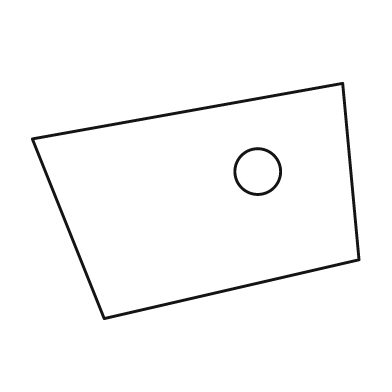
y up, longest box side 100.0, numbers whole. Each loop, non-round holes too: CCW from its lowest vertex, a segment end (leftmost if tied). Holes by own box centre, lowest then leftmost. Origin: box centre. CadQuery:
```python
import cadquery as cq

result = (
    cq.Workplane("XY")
    .moveTo(-28.0, -36.0)
    .lineTo(50.0, -18.0)
    .lineTo(45.0, 36.0)
    .lineTo(-50.0, 19.0)
    .close()
    .moveTo(19.0, 9.0)
    .circle(7.0)
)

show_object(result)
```